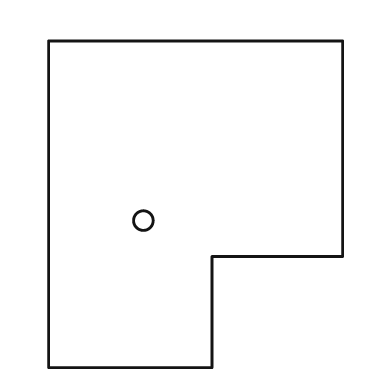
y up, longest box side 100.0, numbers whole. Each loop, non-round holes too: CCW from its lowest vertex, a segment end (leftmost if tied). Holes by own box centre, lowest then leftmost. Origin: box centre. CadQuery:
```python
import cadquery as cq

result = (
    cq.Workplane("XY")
    .moveTo(-45.0, -50.0)
    .lineTo(5.0, -50.0)
    .lineTo(5.0, -16.0)
    .lineTo(45.0, -16.0)
    .lineTo(45.0, 50.0)
    .lineTo(-45.0, 50.0)
    .close()
    .moveTo(-16.0, -5.0)
    .circle(3.0)
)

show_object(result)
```